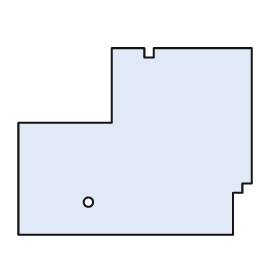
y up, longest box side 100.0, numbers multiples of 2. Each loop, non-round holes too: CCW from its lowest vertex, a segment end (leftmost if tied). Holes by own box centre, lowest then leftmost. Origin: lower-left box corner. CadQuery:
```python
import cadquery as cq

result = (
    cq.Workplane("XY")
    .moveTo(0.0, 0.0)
    .lineTo(92.0, 0.0)
    .lineTo(92.0, 18.0)
    .lineTo(96.0, 18.0)
    .lineTo(96.0, 22.0)
    .lineTo(100.0, 22.0)
    .lineTo(100.0, 80.0)
    .lineTo(58.0, 80.0)
    .lineTo(58.0, 76.0)
    .lineTo(54.0, 76.0)
    .lineTo(54.0, 80.0)
    .lineTo(40.0, 80.0)
    .lineTo(40.0, 48.0)
    .lineTo(0.0, 48.0)
    .close()
    .moveTo(30.0, 14.0)
    .circle(2.0)
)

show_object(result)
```